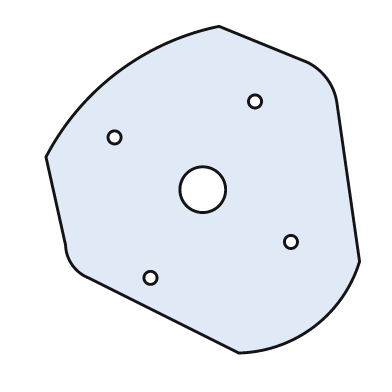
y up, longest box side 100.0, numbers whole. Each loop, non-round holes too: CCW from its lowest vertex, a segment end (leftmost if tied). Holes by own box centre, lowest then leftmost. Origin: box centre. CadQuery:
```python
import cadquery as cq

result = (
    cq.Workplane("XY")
    .moveTo(11.0, -50.0)
    .threePointArc((34.0, -42.0), (48.0, -22.0))
    .lineTo(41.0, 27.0)
    .threePointArc((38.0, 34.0), (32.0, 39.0))
    .lineTo(5.0, 50.0)
    .threePointArc((-26.0, 36.0), (-48.0, 10.0))
    .lineTo(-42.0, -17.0)
    .threePointArc((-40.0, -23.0), (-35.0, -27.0))
    .close()
    .moveTo(-16.0, -27.0)
    .circle(2.0)
    .moveTo(27.0, -16.0)
    .circle(2.0)
    .moveTo(0.0, 0.0)
    .circle(7.0)
    .moveTo(-27.0, 16.0)
    .circle(2.0)
    .moveTo(16.0, 27.0)
    .circle(2.0)
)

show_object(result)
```